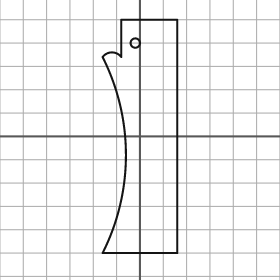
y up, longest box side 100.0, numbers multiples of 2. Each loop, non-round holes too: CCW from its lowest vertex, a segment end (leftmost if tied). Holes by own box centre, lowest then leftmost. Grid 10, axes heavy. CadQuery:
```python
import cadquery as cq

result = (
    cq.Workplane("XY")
    .moveTo(-16.0, -50.0)
    .lineTo(16.0, -50.0)
    .lineTo(16.0, 50.0)
    .lineTo(-8.0, 50.0)
    .lineTo(-8.0, 34.0)
    .threePointArc((-12.0, 36.0), (-16.0, 34.0))
    .threePointArc((-6.0, -8.0), (-16.0, -50.0))
    .close()
    .moveTo(-2.0, 40.0)
    .circle(2.0)
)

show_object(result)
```